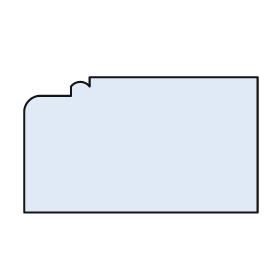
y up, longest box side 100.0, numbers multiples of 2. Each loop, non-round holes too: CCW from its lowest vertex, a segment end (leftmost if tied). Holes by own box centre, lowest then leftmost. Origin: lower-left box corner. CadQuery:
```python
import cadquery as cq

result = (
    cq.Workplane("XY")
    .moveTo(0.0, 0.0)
    .lineTo(100.0, 0.0)
    .lineTo(100.0, 58.0)
    .lineTo(28.0, 58.0)
    .lineTo(28.0, 54.0)
    .threePointArc((24.0, 56.0), (20.0, 54.0))
    .lineTo(20.0, 50.0)
    .lineTo(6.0, 50.0)
    .threePointArc((2.0, 48.0), (0.0, 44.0))
    .close()
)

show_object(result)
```